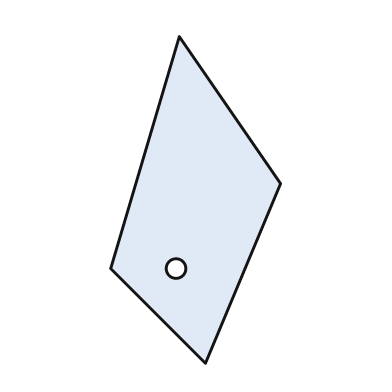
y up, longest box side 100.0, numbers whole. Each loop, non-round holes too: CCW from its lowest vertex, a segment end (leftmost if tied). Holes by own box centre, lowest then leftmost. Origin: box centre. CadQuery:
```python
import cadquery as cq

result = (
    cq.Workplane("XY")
    .moveTo(3.0, -50.0)
    .lineTo(26.0, 5.0)
    .lineTo(-5.0, 50.0)
    .lineTo(-26.0, -21.0)
    .close()
    .moveTo(-6.0, -21.0)
    .circle(3.0)
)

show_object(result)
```